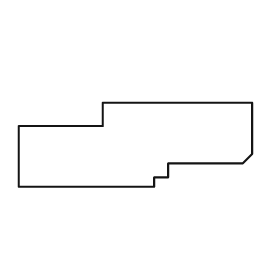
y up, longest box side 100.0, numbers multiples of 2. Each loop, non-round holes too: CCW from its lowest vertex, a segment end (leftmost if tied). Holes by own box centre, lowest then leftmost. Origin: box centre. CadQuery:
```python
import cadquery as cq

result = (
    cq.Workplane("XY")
    .moveTo(-50.0, -18.0)
    .lineTo(8.0, -18.0)
    .lineTo(8.0, -14.0)
    .lineTo(14.0, -14.0)
    .lineTo(14.0, -8.0)
    .lineTo(46.0, -8.0)
    .lineTo(50.0, -4.0)
    .lineTo(50.0, 18.0)
    .lineTo(-14.0, 18.0)
    .lineTo(-14.0, 8.0)
    .lineTo(-50.0, 8.0)
    .close()
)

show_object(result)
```